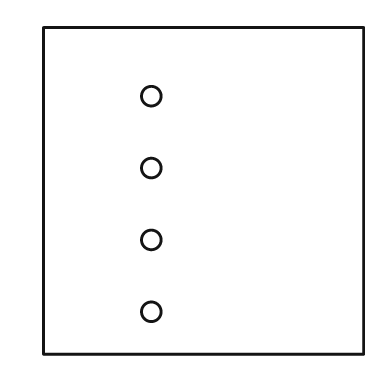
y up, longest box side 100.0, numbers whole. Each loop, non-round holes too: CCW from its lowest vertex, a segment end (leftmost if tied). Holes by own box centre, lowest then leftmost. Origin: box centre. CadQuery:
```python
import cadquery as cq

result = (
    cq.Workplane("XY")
    .moveTo(-49.0, -50.0)
    .lineTo(49.0, -50.0)
    .lineTo(49.0, 50.0)
    .lineTo(-49.0, 50.0)
    .close()
    .moveTo(-16.0, -37.0)
    .circle(3.0)
    .moveTo(-16.0, -15.0)
    .circle(3.0)
    .moveTo(-16.0, 7.0)
    .circle(3.0)
    .moveTo(-16.0, 29.0)
    .circle(3.0)
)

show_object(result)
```